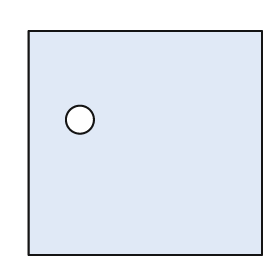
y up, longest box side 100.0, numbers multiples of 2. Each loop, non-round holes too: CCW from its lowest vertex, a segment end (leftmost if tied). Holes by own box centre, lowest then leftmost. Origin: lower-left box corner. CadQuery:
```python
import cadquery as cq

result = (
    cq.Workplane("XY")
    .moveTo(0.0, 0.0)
    .lineTo(100.0, 0.0)
    .lineTo(100.0, 96.0)
    .lineTo(0.0, 96.0)
    .close()
    .moveTo(22.0, 58.0)
    .circle(6.0)
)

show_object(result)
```